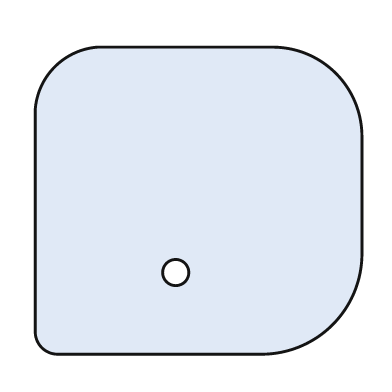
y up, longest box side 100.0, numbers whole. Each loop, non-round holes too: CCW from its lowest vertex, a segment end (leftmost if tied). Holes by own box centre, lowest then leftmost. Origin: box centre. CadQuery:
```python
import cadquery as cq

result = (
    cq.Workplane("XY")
    .moveTo(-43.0, -47.0)
    .lineTo(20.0, -47.0)
    .threePointArc((41.0, -38.0), (50.0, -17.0))
    .lineTo(50.0, 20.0)
    .threePointArc((42.0, 39.0), (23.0, 47.0))
    .lineTo(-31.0, 47.0)
    .threePointArc((-44.0, 41.0), (-50.0, 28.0))
    .lineTo(-50.0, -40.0)
    .threePointArc((-48.0, -45.0), (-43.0, -47.0))
    .close()
    .moveTo(-7.0, -22.0)
    .circle(4.0)
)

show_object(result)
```